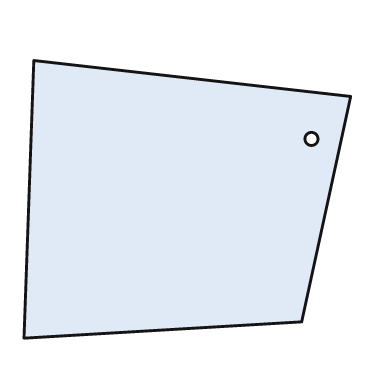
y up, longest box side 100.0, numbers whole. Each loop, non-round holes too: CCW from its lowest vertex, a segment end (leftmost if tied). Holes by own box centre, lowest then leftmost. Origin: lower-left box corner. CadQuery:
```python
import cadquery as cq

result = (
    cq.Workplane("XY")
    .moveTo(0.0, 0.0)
    .lineTo(85.0, 5.0)
    .lineTo(100.0, 74.0)
    .lineTo(3.0, 85.0)
    .close()
    .moveTo(88.0, 61.0)
    .circle(2.0)
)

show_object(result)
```